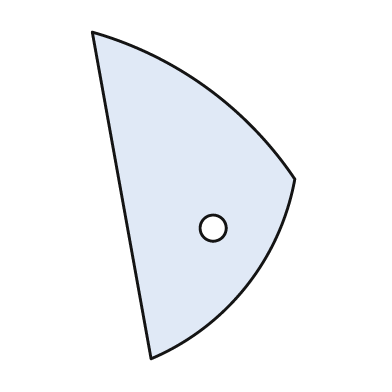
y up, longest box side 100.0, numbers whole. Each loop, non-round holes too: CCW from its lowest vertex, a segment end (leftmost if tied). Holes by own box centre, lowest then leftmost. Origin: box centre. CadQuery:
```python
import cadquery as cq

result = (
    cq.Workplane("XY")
    .moveTo(-13.0, -50.0)
    .threePointArc((16.0, -28.0), (31.0, 5.0))
    .threePointArc((4.0, 33.0), (-31.0, 50.0))
    .close()
    .moveTo(6.0, -10.0)
    .circle(4.0)
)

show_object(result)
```